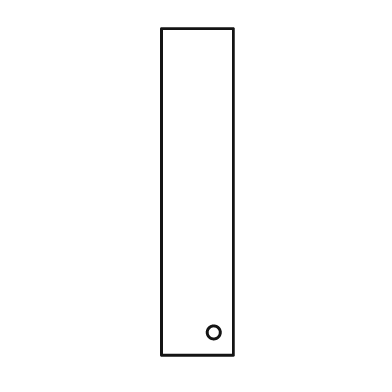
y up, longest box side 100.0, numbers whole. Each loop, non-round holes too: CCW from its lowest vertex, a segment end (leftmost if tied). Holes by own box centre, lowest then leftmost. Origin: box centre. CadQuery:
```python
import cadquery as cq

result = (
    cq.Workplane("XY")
    .moveTo(-11.0, -50.0)
    .lineTo(11.0, -50.0)
    .lineTo(11.0, 50.0)
    .lineTo(-11.0, 50.0)
    .close()
    .moveTo(5.0, -43.0)
    .circle(2.0)
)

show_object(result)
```